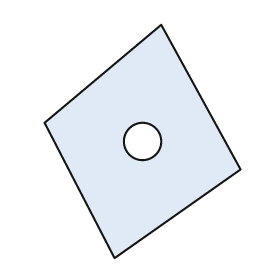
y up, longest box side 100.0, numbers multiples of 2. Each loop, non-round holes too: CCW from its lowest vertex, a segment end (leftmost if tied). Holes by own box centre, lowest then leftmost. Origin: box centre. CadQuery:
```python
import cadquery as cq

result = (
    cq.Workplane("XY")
    .moveTo(-12.0, -50.0)
    .lineTo(42.0, -12.0)
    .lineTo(8.0, 50.0)
    .lineTo(-42.0, 8.0)
    .close()
    .moveTo(0.0, 0.0)
    .circle(8.0)
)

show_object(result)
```